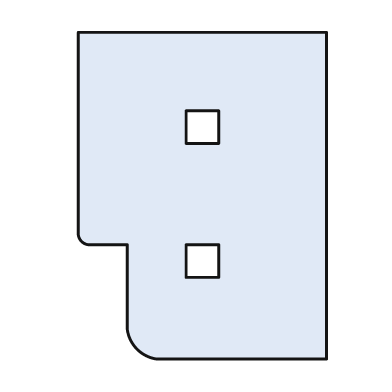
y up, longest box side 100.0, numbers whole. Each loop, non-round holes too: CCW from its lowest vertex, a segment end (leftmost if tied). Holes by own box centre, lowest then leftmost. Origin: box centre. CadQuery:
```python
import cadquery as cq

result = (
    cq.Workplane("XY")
    .moveTo(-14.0, -50.0)
    .lineTo(38.0, -50.0)
    .lineTo(38.0, 50.0)
    .lineTo(-38.0, 50.0)
    .lineTo(-38.0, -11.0)
    .threePointArc((-37.0, -14.0), (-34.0, -15.0))
    .lineTo(-23.0, -15.0)
    .lineTo(-23.0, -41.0)
    .threePointArc((-20.0, -47.0), (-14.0, -50.0))
    .close()
    .moveTo(-5.0, -25.0)
    .lineTo(5.0, -25.0)
    .lineTo(5.0, -15.0)
    .lineTo(-5.0, -15.0)
    .close()
    .moveTo(-5.0, 16.0)
    .lineTo(5.0, 16.0)
    .lineTo(5.0, 26.0)
    .lineTo(-5.0, 26.0)
    .close()
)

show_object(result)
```